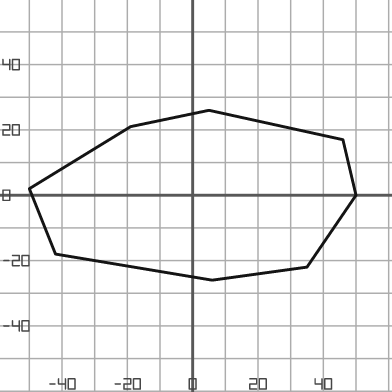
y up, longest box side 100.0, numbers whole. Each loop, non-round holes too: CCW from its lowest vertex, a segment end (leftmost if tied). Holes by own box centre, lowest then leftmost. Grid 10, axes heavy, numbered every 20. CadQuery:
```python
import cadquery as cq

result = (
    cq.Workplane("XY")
    .moveTo(6.0, -26.0)
    .lineTo(35.0, -22.0)
    .lineTo(50.0, 0.0)
    .lineTo(46.0, 17.0)
    .lineTo(5.0, 26.0)
    .lineTo(-19.0, 21.0)
    .lineTo(-50.0, 2.0)
    .lineTo(-42.0, -18.0)
    .close()
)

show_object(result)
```